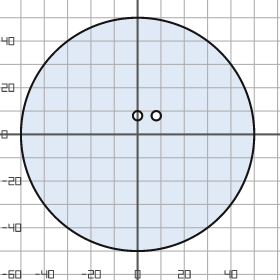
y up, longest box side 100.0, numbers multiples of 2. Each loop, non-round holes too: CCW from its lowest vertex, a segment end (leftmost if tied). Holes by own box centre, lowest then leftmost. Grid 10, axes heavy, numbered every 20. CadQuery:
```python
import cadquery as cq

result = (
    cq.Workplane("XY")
    .moveTo(0.0, 0.0)
    .circle(50.0)
    .moveTo(0.0, 8.0)
    .circle(2.0)
    .moveTo(8.0, 8.0)
    .circle(2.0)
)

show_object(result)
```